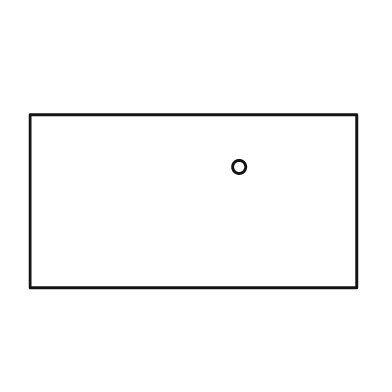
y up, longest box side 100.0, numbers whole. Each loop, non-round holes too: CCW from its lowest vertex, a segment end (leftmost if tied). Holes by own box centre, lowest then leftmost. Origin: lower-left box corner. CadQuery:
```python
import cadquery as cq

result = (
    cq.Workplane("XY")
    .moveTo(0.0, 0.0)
    .lineTo(100.0, 0.0)
    .lineTo(100.0, 53.0)
    .lineTo(0.0, 53.0)
    .close()
    .moveTo(64.0, 37.0)
    .circle(2.0)
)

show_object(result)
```